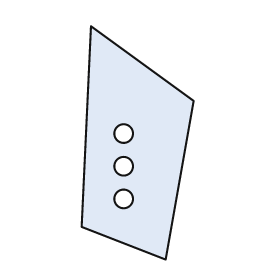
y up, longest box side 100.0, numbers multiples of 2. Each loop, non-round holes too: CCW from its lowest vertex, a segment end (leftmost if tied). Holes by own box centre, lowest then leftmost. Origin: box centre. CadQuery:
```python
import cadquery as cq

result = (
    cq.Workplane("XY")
    .moveTo(12.0, -50.0)
    .lineTo(24.0, 18.0)
    .lineTo(-20.0, 50.0)
    .lineTo(-24.0, -36.0)
    .close()
    .moveTo(-6.0, -24.0)
    .circle(4.0)
    .moveTo(-6.0, -10.0)
    .circle(4.0)
    .moveTo(-6.0, 4.0)
    .circle(4.0)
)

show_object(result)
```